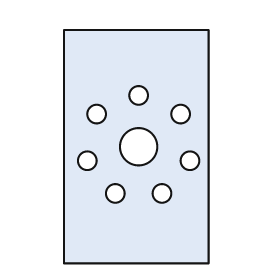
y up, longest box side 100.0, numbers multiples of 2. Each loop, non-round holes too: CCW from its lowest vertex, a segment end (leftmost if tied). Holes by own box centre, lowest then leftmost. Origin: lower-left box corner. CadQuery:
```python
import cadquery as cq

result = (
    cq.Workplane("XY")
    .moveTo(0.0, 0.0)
    .lineTo(62.0, 0.0)
    .lineTo(62.0, 100.0)
    .lineTo(0.0, 100.0)
    .close()
    .moveTo(22.0, 30.0)
    .circle(4.0)
    .moveTo(42.0, 30.0)
    .circle(4.0)
    .moveTo(10.0, 44.0)
    .circle(4.0)
    .moveTo(54.0, 44.0)
    .circle(4.0)
    .moveTo(32.0, 50.0)
    .circle(8.0)
    .moveTo(14.0, 64.0)
    .circle(4.0)
    .moveTo(50.0, 64.0)
    .circle(4.0)
    .moveTo(32.0, 72.0)
    .circle(4.0)
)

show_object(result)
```